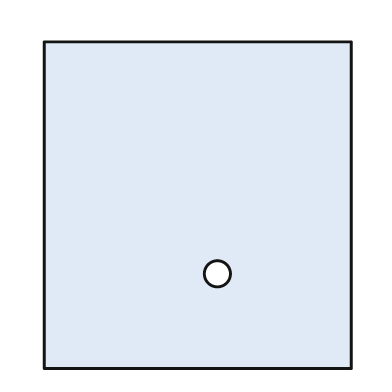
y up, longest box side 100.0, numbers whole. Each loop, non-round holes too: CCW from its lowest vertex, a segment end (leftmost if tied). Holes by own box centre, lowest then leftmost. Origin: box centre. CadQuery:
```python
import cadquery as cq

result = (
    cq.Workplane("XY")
    .moveTo(-47.0, -50.0)
    .lineTo(47.0, -50.0)
    .lineTo(47.0, 50.0)
    .lineTo(-47.0, 50.0)
    .close()
    .moveTo(6.0, -21.0)
    .circle(4.0)
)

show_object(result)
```